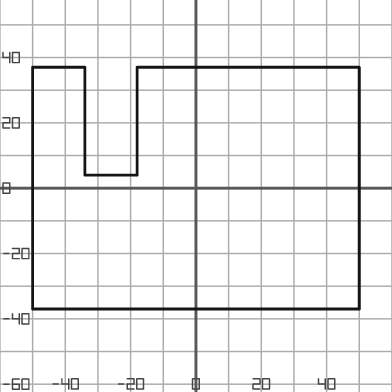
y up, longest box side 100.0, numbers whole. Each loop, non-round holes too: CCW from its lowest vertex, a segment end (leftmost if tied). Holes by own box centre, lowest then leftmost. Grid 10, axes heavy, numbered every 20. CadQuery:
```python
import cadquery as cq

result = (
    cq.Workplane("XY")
    .moveTo(-50.0, -37.0)
    .lineTo(50.0, -37.0)
    .lineTo(50.0, 37.0)
    .lineTo(-18.0, 37.0)
    .lineTo(-18.0, 4.0)
    .lineTo(-34.0, 4.0)
    .lineTo(-34.0, 37.0)
    .lineTo(-50.0, 37.0)
    .close()
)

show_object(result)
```